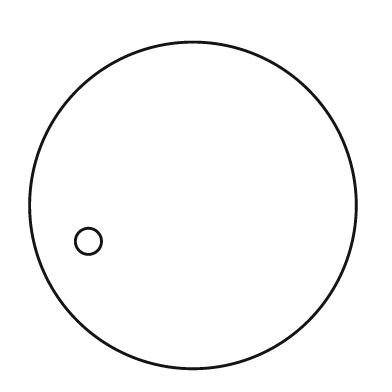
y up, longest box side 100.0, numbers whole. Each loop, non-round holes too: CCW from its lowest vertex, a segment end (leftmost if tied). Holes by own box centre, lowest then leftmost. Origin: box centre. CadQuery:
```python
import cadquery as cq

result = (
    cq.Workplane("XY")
    .moveTo(0.0, 0.0)
    .circle(50.0)
    .moveTo(-32.0, -11.0)
    .circle(4.0)
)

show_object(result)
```